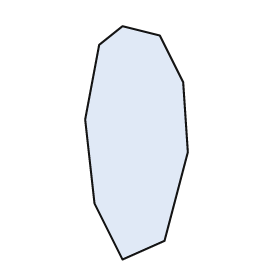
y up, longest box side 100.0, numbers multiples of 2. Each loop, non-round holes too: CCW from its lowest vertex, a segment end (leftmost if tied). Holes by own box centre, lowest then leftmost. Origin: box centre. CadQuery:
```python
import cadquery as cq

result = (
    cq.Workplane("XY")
    .moveTo(-6.0, -50.0)
    .lineTo(12.0, -42.0)
    .lineTo(22.0, -4.0)
    .lineTo(20.0, 26.0)
    .lineTo(10.0, 46.0)
    .lineTo(-6.0, 50.0)
    .lineTo(-16.0, 42.0)
    .lineTo(-22.0, 10.0)
    .lineTo(-18.0, -26.0)
    .close()
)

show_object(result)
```